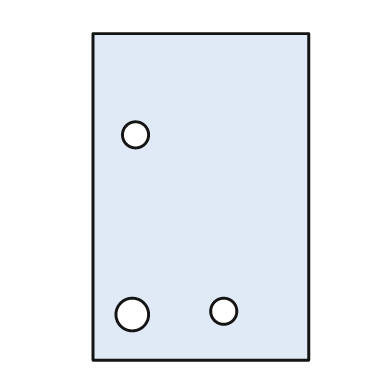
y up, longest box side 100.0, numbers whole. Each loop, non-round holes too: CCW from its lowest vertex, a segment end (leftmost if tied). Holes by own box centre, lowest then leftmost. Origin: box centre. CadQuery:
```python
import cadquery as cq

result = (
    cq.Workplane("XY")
    .moveTo(-33.0, -50.0)
    .lineTo(33.0, -50.0)
    .lineTo(33.0, 50.0)
    .lineTo(-33.0, 50.0)
    .close()
    .moveTo(-21.0, -36.0)
    .circle(5.0)
    .moveTo(7.0, -35.0)
    .circle(4.0)
    .moveTo(-20.0, 19.0)
    .circle(4.0)
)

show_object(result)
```